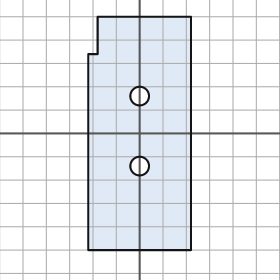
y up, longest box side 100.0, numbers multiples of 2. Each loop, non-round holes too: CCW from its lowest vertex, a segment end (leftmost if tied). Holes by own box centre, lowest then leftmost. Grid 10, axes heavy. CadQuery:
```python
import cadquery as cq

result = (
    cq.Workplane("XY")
    .moveTo(-22.0, -50.0)
    .lineTo(22.0, -50.0)
    .lineTo(22.0, 50.0)
    .lineTo(-18.0, 50.0)
    .lineTo(-18.0, 34.0)
    .lineTo(-22.0, 34.0)
    .close()
    .moveTo(0.0, -14.0)
    .circle(4.0)
    .moveTo(0.0, 16.0)
    .circle(4.0)
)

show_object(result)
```